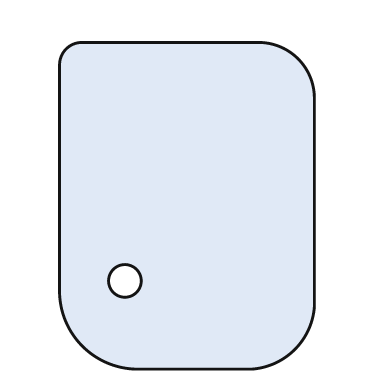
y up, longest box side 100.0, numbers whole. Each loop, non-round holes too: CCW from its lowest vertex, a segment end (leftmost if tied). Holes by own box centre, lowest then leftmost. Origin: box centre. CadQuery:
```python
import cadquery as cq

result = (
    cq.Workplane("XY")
    .moveTo(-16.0, -50.0)
    .lineTo(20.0, -50.0)
    .threePointArc((33.0, -44.0), (39.0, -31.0))
    .lineTo(39.0, 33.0)
    .threePointArc((34.0, 45.0), (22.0, 50.0))
    .lineTo(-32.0, 50.0)
    .threePointArc((-37.0, 48.0), (-39.0, 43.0))
    .lineTo(-39.0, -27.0)
    .threePointArc((-32.0, -43.0), (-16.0, -50.0))
    .close()
    .moveTo(-19.0, -23.0)
    .circle(5.0)
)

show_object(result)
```